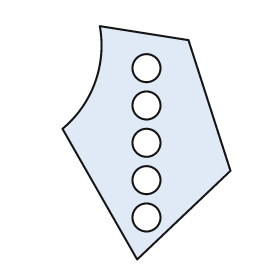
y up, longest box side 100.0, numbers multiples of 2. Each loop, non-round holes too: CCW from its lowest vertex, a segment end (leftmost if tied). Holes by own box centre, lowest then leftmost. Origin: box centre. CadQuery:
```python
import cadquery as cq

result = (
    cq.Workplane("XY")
    .moveTo(-4.0, -50.0)
    .lineTo(36.0, -12.0)
    .lineTo(18.0, 44.0)
    .lineTo(-20.0, 50.0)
    .threePointArc((-22.0, 26.0), (-36.0, 6.0))
    .close()
    .moveTo(0.0, -32.0)
    .circle(6.0)
    .moveTo(0.0, -16.0)
    .circle(6.0)
    .moveTo(0.0, 0.0)
    .circle(6.0)
    .moveTo(0.0, 16.0)
    .circle(6.0)
    .moveTo(0.0, 32.0)
    .circle(6.0)
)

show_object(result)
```